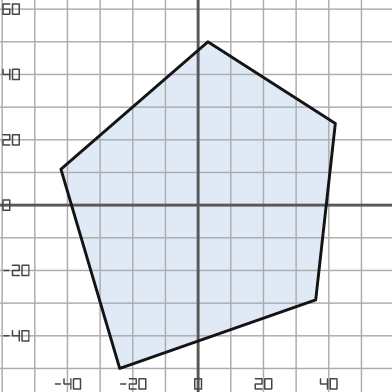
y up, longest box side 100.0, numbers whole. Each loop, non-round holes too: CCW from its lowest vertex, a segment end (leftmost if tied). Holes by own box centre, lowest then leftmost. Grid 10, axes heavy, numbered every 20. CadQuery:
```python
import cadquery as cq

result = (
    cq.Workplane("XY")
    .moveTo(-24.0, -50.0)
    .lineTo(36.0, -29.0)
    .lineTo(42.0, 25.0)
    .lineTo(3.0, 50.0)
    .lineTo(-42.0, 11.0)
    .close()
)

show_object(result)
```